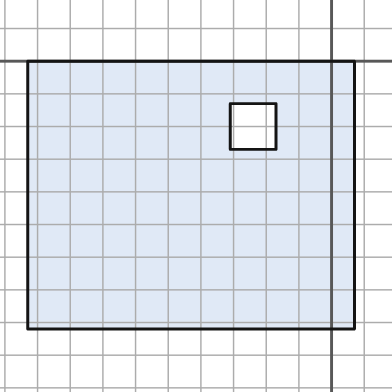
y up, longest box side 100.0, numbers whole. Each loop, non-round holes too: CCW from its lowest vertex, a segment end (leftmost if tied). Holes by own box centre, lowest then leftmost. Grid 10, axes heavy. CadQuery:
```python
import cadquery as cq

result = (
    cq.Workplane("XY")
    .moveTo(-93.0, -82.0)
    .lineTo(7.0, -82.0)
    .lineTo(7.0, 0.0)
    .lineTo(-93.0, 0.0)
    .close()
    .moveTo(-31.0, -27.0)
    .lineTo(-17.0, -27.0)
    .lineTo(-17.0, -13.0)
    .lineTo(-31.0, -13.0)
    .close()
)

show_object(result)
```